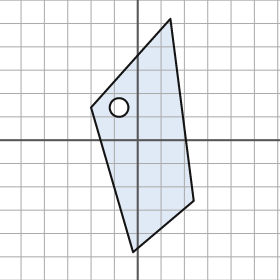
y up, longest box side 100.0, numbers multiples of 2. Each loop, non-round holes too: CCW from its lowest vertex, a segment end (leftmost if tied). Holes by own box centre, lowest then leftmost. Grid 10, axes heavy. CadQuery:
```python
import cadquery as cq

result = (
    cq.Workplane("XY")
    .moveTo(-2.0, -48.0)
    .lineTo(24.0, -26.0)
    .lineTo(14.0, 52.0)
    .lineTo(-20.0, 14.0)
    .close()
    .moveTo(-8.0, 14.0)
    .circle(4.0)
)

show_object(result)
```